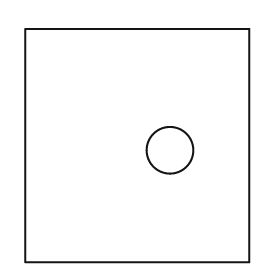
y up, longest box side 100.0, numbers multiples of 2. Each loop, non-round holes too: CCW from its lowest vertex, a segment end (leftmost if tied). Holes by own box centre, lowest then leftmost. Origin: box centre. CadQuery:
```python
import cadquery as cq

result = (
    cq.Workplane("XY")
    .moveTo(-48.0, -50.0)
    .lineTo(48.0, -50.0)
    .lineTo(48.0, 50.0)
    .lineTo(-48.0, 50.0)
    .close()
    .moveTo(14.0, -2.0)
    .circle(10.0)
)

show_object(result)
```